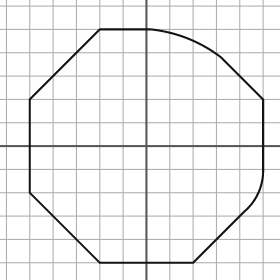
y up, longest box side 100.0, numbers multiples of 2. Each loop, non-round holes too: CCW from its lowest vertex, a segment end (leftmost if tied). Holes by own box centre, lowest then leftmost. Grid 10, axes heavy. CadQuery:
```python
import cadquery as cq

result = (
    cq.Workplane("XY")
    .moveTo(-20.0, -50.0)
    .lineTo(20.0, -50.0)
    .lineTo(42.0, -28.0)
    .threePointArc((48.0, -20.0), (50.0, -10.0))
    .lineTo(50.0, 20.0)
    .lineTo(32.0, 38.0)
    .threePointArc((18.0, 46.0), (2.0, 50.0))
    .lineTo(-20.0, 50.0)
    .lineTo(-50.0, 20.0)
    .lineTo(-50.0, -20.0)
    .close()
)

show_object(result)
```